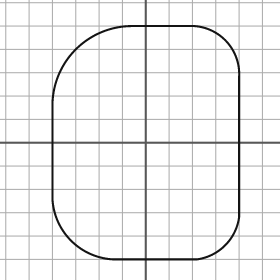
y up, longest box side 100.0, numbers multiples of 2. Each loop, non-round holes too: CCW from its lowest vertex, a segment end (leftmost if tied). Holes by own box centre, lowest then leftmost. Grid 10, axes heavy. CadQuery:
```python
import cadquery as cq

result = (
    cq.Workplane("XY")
    .moveTo(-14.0, -50.0)
    .lineTo(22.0, -50.0)
    .threePointArc((34.0, -44.0), (40.0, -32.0))
    .lineTo(40.0, 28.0)
    .threePointArc((34.0, 44.0), (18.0, 50.0))
    .lineTo(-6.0, 50.0)
    .threePointArc((-30.0, 40.0), (-40.0, 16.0))
    .lineTo(-40.0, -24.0)
    .threePointArc((-32.0, -42.0), (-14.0, -50.0))
    .close()
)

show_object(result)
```